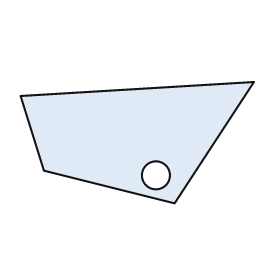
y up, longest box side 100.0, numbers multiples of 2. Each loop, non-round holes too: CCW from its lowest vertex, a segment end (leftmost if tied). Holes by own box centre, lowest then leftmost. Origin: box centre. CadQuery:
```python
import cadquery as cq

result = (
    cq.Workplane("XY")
    .moveTo(16.0, -26.0)
    .lineTo(50.0, 26.0)
    .lineTo(-50.0, 20.0)
    .lineTo(-40.0, -12.0)
    .close()
    .moveTo(8.0, -14.0)
    .circle(6.0)
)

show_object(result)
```